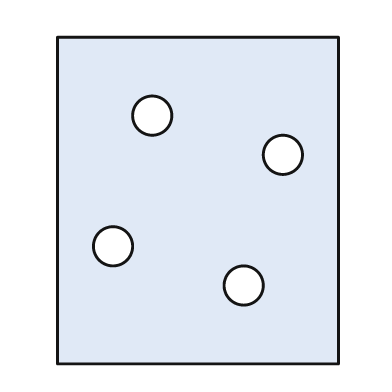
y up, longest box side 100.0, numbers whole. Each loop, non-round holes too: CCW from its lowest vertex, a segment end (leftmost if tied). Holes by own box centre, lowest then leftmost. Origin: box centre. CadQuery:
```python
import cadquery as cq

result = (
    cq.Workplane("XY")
    .moveTo(-43.0, -50.0)
    .lineTo(43.0, -50.0)
    .lineTo(43.0, 50.0)
    .lineTo(-43.0, 50.0)
    .close()
    .moveTo(14.0, -26.0)
    .circle(6.0)
    .moveTo(-26.0, -14.0)
    .circle(6.0)
    .moveTo(26.0, 14.0)
    .circle(6.0)
    .moveTo(-14.0, 26.0)
    .circle(6.0)
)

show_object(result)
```